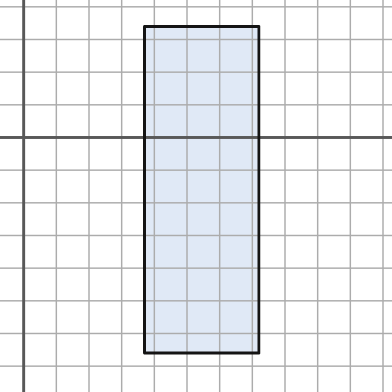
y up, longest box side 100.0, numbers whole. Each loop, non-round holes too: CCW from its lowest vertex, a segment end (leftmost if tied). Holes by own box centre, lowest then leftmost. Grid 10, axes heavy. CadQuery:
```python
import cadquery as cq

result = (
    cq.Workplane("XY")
    .moveTo(37.0, -66.0)
    .lineTo(72.0, -66.0)
    .lineTo(72.0, 34.0)
    .lineTo(37.0, 34.0)
    .close()
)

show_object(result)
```